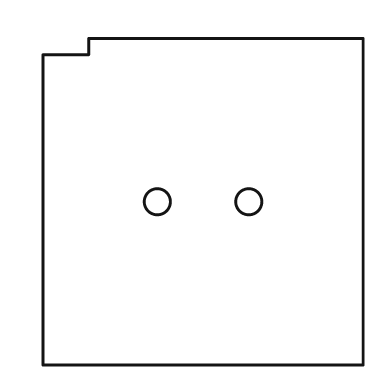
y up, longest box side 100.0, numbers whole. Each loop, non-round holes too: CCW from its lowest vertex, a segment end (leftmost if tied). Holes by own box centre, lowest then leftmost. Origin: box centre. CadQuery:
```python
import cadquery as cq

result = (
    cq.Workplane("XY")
    .moveTo(-49.0, -50.0)
    .lineTo(49.0, -50.0)
    .lineTo(49.0, 50.0)
    .lineTo(-35.0, 50.0)
    .lineTo(-35.0, 45.0)
    .lineTo(-49.0, 45.0)
    .close()
    .moveTo(-14.0, 0.0)
    .circle(4.0)
    .moveTo(14.0, 0.0)
    .circle(4.0)
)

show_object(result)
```